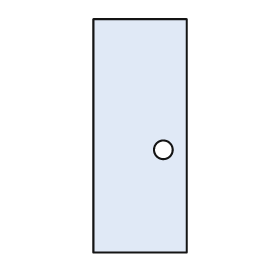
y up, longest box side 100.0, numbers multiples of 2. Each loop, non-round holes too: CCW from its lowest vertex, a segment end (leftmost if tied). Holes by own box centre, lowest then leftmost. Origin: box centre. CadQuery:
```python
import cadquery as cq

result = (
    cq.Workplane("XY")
    .moveTo(-20.0, -50.0)
    .lineTo(20.0, -50.0)
    .lineTo(20.0, 50.0)
    .lineTo(-20.0, 50.0)
    .close()
    .moveTo(10.0, -6.0)
    .circle(4.0)
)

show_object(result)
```